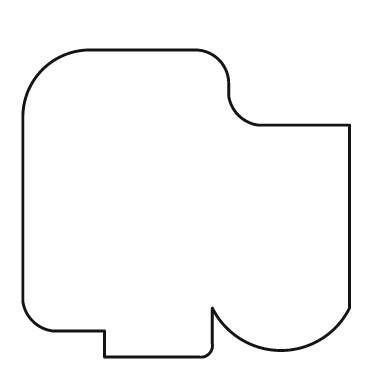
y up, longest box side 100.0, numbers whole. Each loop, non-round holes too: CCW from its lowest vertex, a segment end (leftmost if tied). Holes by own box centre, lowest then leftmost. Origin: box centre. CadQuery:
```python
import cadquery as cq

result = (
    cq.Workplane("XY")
    .moveTo(-25.0, -47.0)
    .lineTo(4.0, -47.0)
    .threePointArc((7.0, -46.0), (8.0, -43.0))
    .lineTo(8.0, -32.0)
    .threePointArc((29.0, -45.0), (50.0, -32.0))
    .lineTo(50.0, 24.0)
    .lineTo(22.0, 24.0)
    .threePointArc((16.0, 27.0), (13.0, 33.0))
    .lineTo(13.0, 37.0)
    .threePointArc((10.0, 44.0), (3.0, 47.0))
    .lineTo(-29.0, 47.0)
    .threePointArc((-44.0, 41.0), (-50.0, 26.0))
    .lineTo(-50.0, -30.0)
    .threePointArc((-47.0, -36.0), (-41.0, -39.0))
    .lineTo(-25.0, -39.0)
    .close()
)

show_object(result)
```